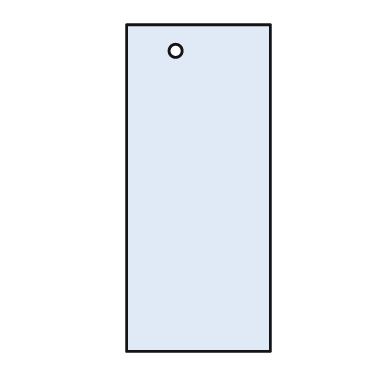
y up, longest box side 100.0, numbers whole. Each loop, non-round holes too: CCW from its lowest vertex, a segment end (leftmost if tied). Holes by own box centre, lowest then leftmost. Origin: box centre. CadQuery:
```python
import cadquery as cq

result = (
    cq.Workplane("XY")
    .moveTo(-22.0, -50.0)
    .lineTo(22.0, -50.0)
    .lineTo(22.0, 50.0)
    .lineTo(-22.0, 50.0)
    .close()
    .moveTo(-7.0, 42.0)
    .circle(2.0)
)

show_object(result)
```